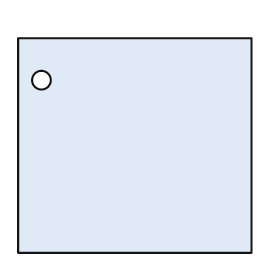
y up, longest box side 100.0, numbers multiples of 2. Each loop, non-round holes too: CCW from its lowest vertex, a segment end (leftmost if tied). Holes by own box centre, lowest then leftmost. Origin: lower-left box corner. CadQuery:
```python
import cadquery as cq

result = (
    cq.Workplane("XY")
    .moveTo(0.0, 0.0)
    .lineTo(100.0, 0.0)
    .lineTo(100.0, 92.0)
    .lineTo(0.0, 92.0)
    .close()
    .moveTo(10.0, 74.0)
    .circle(4.0)
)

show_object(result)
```